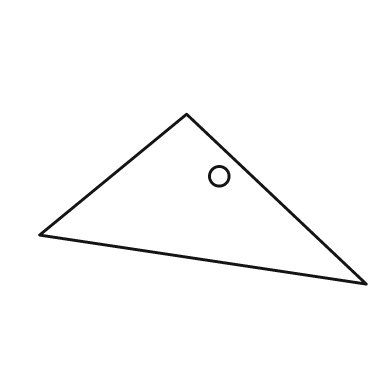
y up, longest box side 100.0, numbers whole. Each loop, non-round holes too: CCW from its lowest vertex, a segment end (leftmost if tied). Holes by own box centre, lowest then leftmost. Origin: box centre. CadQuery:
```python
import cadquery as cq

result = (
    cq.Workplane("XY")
    .moveTo(50.0, -26.0)
    .lineTo(-5.0, 26.0)
    .lineTo(-50.0, -11.0)
    .close()
    .moveTo(5.0, 7.0)
    .circle(3.0)
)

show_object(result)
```